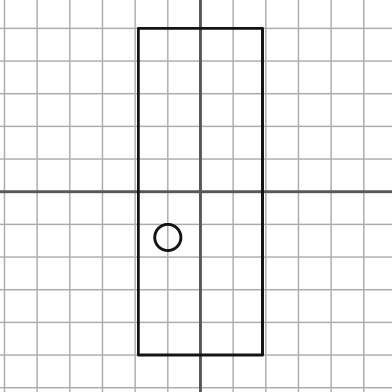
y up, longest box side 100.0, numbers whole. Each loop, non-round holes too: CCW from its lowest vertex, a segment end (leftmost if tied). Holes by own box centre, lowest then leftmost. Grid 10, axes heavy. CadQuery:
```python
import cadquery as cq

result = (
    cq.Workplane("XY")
    .moveTo(-19.0, -50.0)
    .lineTo(19.0, -50.0)
    .lineTo(19.0, 50.0)
    .lineTo(-19.0, 50.0)
    .close()
    .moveTo(-10.0, -14.0)
    .circle(4.0)
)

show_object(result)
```